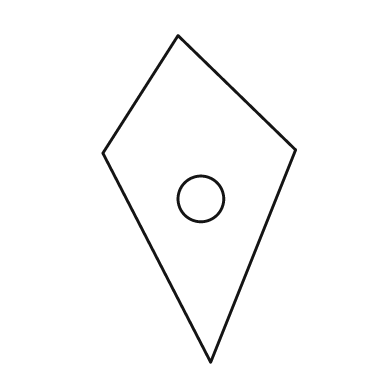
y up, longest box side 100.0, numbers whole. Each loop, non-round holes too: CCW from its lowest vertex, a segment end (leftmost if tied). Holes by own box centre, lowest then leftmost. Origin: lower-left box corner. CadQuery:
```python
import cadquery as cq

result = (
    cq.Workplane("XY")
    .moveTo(33.0, 0.0)
    .lineTo(59.0, 65.0)
    .lineTo(23.0, 100.0)
    .lineTo(0.0, 64.0)
    .close()
    .moveTo(30.0, 50.0)
    .circle(7.0)
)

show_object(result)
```